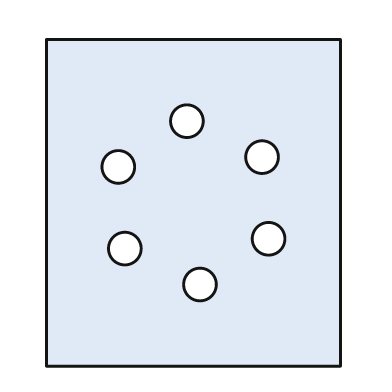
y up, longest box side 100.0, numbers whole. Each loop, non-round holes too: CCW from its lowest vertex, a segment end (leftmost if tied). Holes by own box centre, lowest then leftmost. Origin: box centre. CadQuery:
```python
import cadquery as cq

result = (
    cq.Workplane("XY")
    .moveTo(-45.0, -50.0)
    .lineTo(45.0, -50.0)
    .lineTo(45.0, 50.0)
    .lineTo(-45.0, 50.0)
    .close()
    .moveTo(2.0, -25.0)
    .circle(5.0)
    .moveTo(-21.0, -14.0)
    .circle(5.0)
    .moveTo(23.0, -11.0)
    .circle(5.0)
    .moveTo(-23.0, 11.0)
    .circle(5.0)
    .moveTo(21.0, 14.0)
    .circle(5.0)
    .moveTo(-2.0, 25.0)
    .circle(5.0)
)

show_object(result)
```